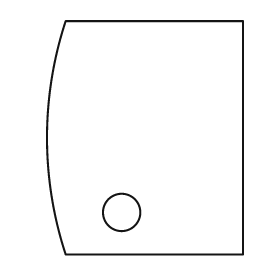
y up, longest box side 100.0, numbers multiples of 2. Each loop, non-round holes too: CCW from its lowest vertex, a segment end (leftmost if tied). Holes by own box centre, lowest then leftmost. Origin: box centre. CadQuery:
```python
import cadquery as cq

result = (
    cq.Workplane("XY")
    .moveTo(-34.0, -50.0)
    .lineTo(42.0, -50.0)
    .lineTo(42.0, 50.0)
    .lineTo(-34.0, 50.0)
    .threePointArc((-42.0, 0.0), (-34.0, -50.0))
    .close()
    .moveTo(-10.0, -32.0)
    .circle(8.0)
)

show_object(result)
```